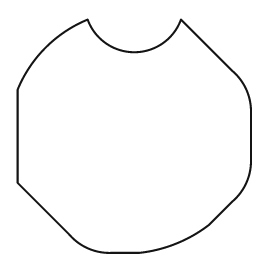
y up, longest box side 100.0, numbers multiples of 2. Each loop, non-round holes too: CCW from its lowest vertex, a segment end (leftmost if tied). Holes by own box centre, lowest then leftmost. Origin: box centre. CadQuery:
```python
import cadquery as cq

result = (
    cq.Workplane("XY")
    .moveTo(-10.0, -50.0)
    .lineTo(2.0, -50.0)
    .threePointArc((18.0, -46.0), (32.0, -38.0))
    .lineTo(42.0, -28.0)
    .threePointArc((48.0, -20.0), (50.0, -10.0))
    .lineTo(50.0, 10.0)
    .threePointArc((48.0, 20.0), (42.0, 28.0))
    .lineTo(20.0, 50.0)
    .threePointArc((0.0, 36.0), (-20.0, 50.0))
    .threePointArc((-38.0, 38.0), (-50.0, 20.0))
    .lineTo(-50.0, -20.0)
    .lineTo(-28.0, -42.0)
    .threePointArc((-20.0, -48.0), (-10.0, -50.0))
    .close()
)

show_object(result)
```